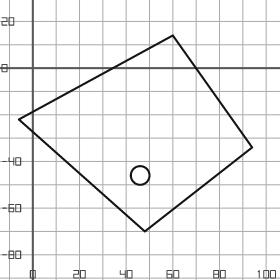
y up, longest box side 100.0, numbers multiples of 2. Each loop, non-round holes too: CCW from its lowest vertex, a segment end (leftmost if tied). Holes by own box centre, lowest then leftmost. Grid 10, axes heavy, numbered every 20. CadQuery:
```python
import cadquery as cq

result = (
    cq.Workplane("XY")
    .moveTo(48.0, -70.0)
    .lineTo(94.0, -34.0)
    .lineTo(60.0, 14.0)
    .lineTo(-6.0, -22.0)
    .close()
    .moveTo(46.0, -46.0)
    .circle(4.0)
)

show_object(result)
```